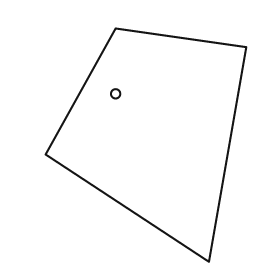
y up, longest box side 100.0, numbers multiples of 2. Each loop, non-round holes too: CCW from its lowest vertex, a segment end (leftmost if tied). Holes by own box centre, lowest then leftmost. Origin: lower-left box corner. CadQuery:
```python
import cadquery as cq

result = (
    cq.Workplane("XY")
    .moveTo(70.0, 0.0)
    .lineTo(86.0, 92.0)
    .lineTo(30.0, 100.0)
    .lineTo(0.0, 46.0)
    .close()
    .moveTo(30.0, 72.0)
    .circle(2.0)
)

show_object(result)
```